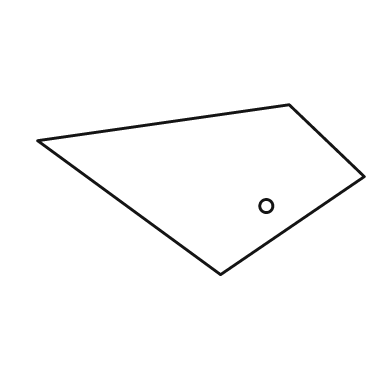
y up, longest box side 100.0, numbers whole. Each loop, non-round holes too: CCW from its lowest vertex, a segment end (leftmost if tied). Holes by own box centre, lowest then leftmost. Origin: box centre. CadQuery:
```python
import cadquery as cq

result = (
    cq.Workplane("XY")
    .moveTo(6.0, -26.0)
    .lineTo(50.0, 4.0)
    .lineTo(27.0, 26.0)
    .lineTo(-50.0, 15.0)
    .close()
    .moveTo(20.0, -5.0)
    .circle(2.0)
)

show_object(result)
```